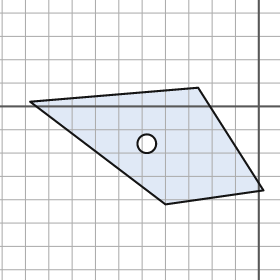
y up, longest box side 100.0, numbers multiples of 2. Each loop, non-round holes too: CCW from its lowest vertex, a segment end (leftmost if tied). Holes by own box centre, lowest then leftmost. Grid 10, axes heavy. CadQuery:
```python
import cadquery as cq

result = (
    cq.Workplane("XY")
    .moveTo(-40.0, -42.0)
    .lineTo(2.0, -36.0)
    .lineTo(-26.0, 8.0)
    .lineTo(-98.0, 2.0)
    .close()
    .moveTo(-48.0, -16.0)
    .circle(4.0)
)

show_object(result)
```